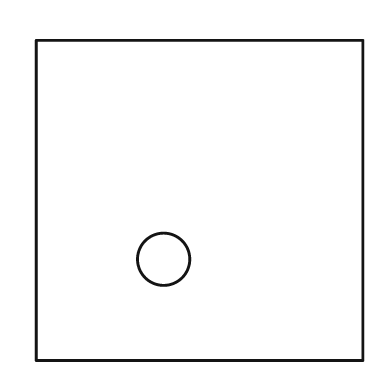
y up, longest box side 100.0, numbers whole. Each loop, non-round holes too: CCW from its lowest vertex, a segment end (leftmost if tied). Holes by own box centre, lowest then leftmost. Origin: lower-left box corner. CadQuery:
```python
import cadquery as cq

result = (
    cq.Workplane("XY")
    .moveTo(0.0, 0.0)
    .lineTo(100.0, 0.0)
    .lineTo(100.0, 98.0)
    .lineTo(0.0, 98.0)
    .close()
    .moveTo(39.0, 31.0)
    .circle(8.0)
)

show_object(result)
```